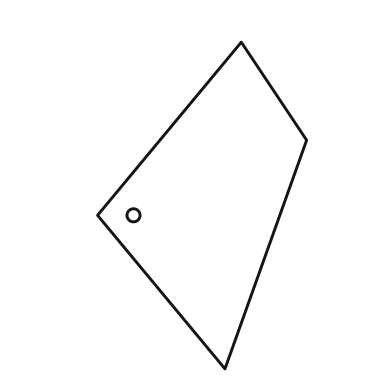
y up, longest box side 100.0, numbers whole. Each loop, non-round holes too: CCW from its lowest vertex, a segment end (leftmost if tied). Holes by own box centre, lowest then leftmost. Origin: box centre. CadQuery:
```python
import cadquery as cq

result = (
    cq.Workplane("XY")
    .moveTo(7.0, -50.0)
    .lineTo(32.0, 20.0)
    .lineTo(12.0, 50.0)
    .lineTo(-32.0, -3.0)
    .close()
    .moveTo(-21.0, -3.0)
    .circle(2.0)
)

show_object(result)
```